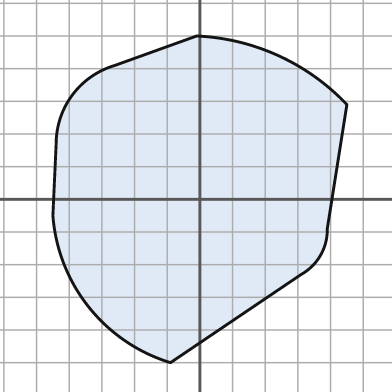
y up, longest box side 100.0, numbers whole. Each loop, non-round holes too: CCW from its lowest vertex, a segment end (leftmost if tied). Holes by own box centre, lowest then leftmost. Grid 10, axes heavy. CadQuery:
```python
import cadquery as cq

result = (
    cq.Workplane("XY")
    .moveTo(-9.0, -50.0)
    .lineTo(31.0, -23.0)
    .threePointArc((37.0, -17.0), (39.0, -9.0))
    .lineTo(45.0, 29.0)
    .threePointArc((24.0, 44.0), (-1.0, 50.0))
    .lineTo(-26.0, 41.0)
    .threePointArc((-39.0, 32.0), (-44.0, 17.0))
    .lineTo(-45.0, -5.0)
    .threePointArc((-34.0, -33.0), (-9.0, -50.0))
    .close()
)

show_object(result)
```